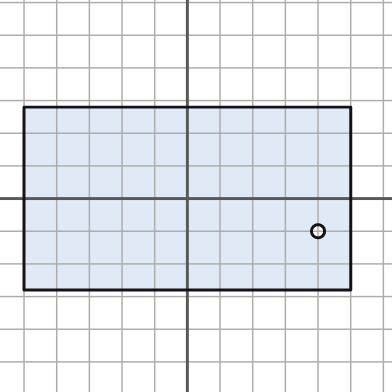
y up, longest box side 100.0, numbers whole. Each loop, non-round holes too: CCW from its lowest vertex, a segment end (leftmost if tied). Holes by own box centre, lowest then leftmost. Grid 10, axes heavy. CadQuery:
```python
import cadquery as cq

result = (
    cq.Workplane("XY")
    .moveTo(-50.0, -28.0)
    .lineTo(50.0, -28.0)
    .lineTo(50.0, 28.0)
    .lineTo(-50.0, 28.0)
    .close()
    .moveTo(40.0, -10.0)
    .circle(2.0)
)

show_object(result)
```